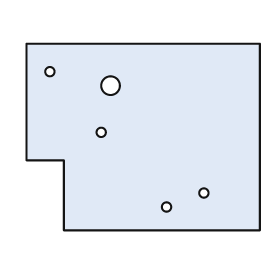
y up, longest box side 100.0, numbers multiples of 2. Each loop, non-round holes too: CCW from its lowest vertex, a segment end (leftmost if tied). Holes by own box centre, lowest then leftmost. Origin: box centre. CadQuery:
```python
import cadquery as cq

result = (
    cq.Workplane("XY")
    .moveTo(-34.0, -40.0)
    .lineTo(50.0, -40.0)
    .lineTo(50.0, 40.0)
    .lineTo(-50.0, 40.0)
    .lineTo(-50.0, -10.0)
    .lineTo(-34.0, -10.0)
    .close()
    .moveTo(10.0, -30.0)
    .circle(2.0)
    .moveTo(26.0, -24.0)
    .circle(2.0)
    .moveTo(-18.0, 2.0)
    .circle(2.0)
    .moveTo(-14.0, 22.0)
    .circle(4.0)
    .moveTo(-40.0, 28.0)
    .circle(2.0)
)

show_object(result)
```